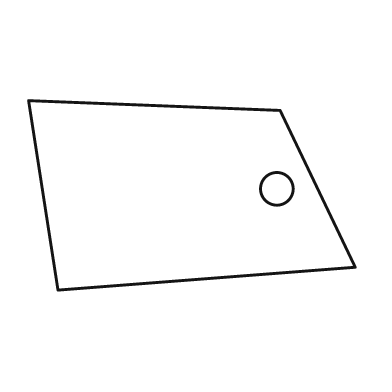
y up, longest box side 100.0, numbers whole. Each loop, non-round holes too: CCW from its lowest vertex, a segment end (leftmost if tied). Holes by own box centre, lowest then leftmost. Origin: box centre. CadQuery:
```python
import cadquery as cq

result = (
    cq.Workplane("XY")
    .moveTo(-41.0, -29.0)
    .lineTo(50.0, -22.0)
    .lineTo(27.0, 26.0)
    .lineTo(-50.0, 29.0)
    .close()
    .moveTo(26.0, 2.0)
    .circle(5.0)
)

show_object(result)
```